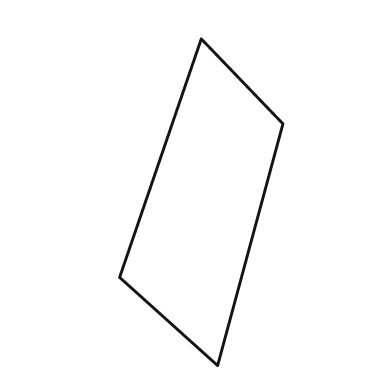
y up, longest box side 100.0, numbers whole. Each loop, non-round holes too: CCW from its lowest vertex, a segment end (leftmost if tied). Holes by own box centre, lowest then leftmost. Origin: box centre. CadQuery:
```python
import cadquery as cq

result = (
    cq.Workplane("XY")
    .moveTo(5.0, -50.0)
    .lineTo(25.0, 24.0)
    .lineTo(0.0, 50.0)
    .lineTo(-25.0, -23.0)
    .close()
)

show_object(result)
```